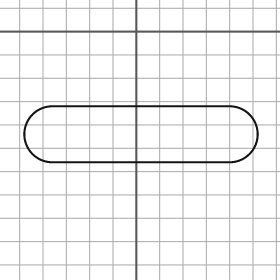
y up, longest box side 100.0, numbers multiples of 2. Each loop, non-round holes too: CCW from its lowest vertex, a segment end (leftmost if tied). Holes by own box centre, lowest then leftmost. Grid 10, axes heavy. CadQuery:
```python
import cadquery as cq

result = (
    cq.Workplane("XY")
    .moveTo(-36.0, -56.0)
    .lineTo(40.0, -56.0)
    .threePointArc((52.0, -44.0), (40.0, -32.0))
    .lineTo(-36.0, -32.0)
    .threePointArc((-48.0, -44.0), (-36.0, -56.0))
    .close()
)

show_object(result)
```